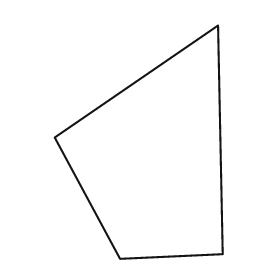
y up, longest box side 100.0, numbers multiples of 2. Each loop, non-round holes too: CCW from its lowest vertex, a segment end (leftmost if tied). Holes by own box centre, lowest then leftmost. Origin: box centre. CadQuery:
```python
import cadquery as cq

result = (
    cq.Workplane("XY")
    .moveTo(-8.0, -50.0)
    .lineTo(36.0, -48.0)
    .lineTo(34.0, 50.0)
    .lineTo(-36.0, 2.0)
    .close()
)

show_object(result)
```